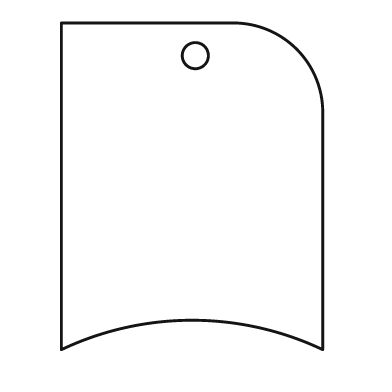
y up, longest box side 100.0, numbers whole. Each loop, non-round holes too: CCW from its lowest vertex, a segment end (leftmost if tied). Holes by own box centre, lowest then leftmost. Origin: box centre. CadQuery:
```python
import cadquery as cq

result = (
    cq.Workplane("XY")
    .moveTo(-40.0, -50.0)
    .threePointArc((0.0, -41.0), (40.0, -50.0))
    .lineTo(40.0, 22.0)
    .threePointArc((32.0, 42.0), (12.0, 50.0))
    .lineTo(-40.0, 50.0)
    .close()
    .moveTo(1.0, 40.0)
    .circle(4.0)
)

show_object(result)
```